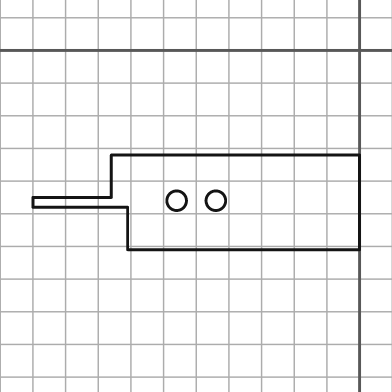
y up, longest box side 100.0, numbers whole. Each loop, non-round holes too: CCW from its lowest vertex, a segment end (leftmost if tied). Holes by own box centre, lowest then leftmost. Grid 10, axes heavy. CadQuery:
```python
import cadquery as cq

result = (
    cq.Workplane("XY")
    .moveTo(-71.0, -61.0)
    .lineTo(0.0, -61.0)
    .lineTo(0.0, -32.0)
    .lineTo(-76.0, -32.0)
    .lineTo(-76.0, -45.0)
    .lineTo(-100.0, -45.0)
    .lineTo(-100.0, -48.0)
    .lineTo(-71.0, -48.0)
    .close()
    .moveTo(-56.0, -46.0)
    .circle(3.0)
    .moveTo(-44.0, -46.0)
    .circle(3.0)
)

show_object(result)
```